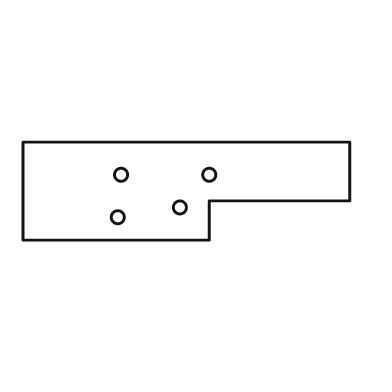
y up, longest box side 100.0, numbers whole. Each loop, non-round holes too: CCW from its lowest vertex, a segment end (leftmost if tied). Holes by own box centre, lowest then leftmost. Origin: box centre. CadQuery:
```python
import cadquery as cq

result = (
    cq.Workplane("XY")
    .moveTo(-50.0, -15.0)
    .lineTo(7.0, -15.0)
    .lineTo(7.0, -3.0)
    .lineTo(50.0, -3.0)
    .lineTo(50.0, 15.0)
    .lineTo(-50.0, 15.0)
    .close()
    .moveTo(-21.0, -8.0)
    .circle(2.0)
    .moveTo(-2.0, -5.0)
    .circle(2.0)
    .moveTo(-20.0, 5.0)
    .circle(2.0)
    .moveTo(7.0, 5.0)
    .circle(2.0)
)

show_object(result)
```